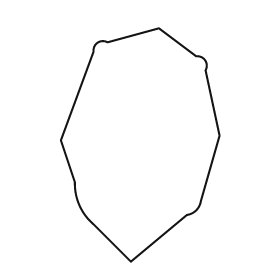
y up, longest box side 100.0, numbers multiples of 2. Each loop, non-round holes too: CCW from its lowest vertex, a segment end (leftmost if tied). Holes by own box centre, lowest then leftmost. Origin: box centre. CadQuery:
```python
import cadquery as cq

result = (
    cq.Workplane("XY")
    .moveTo(-4.0, -50.0)
    .lineTo(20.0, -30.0)
    .threePointArc((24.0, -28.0), (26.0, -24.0))
    .lineTo(34.0, 4.0)
    .lineTo(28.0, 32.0)
    .threePointArc((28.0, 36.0), (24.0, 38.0))
    .lineTo(8.0, 50.0)
    .lineTo(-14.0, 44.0)
    .threePointArc((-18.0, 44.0), (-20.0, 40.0))
    .lineTo(-34.0, 2.0)
    .lineTo(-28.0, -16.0)
    .threePointArc((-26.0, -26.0), (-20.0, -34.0))
    .close()
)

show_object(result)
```